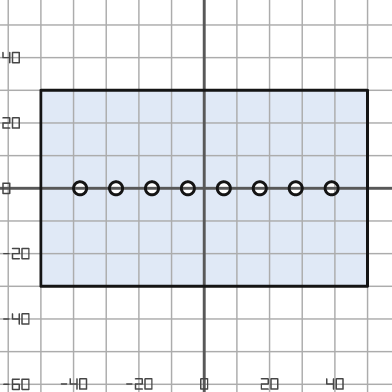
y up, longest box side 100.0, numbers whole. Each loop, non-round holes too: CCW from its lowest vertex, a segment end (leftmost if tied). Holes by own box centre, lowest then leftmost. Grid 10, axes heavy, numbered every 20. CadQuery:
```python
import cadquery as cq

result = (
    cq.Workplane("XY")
    .moveTo(-50.0, -30.0)
    .lineTo(50.0, -30.0)
    .lineTo(50.0, 30.0)
    .lineTo(-50.0, 30.0)
    .close()
    .moveTo(-38.0, 0.0)
    .circle(2.0)
    .moveTo(-27.0, 0.0)
    .circle(2.0)
    .moveTo(-16.0, 0.0)
    .circle(2.0)
    .moveTo(-5.0, 0.0)
    .circle(2.0)
    .moveTo(6.0, 0.0)
    .circle(2.0)
    .moveTo(17.0, 0.0)
    .circle(2.0)
    .moveTo(28.0, 0.0)
    .circle(2.0)
    .moveTo(39.0, 0.0)
    .circle(2.0)
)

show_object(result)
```